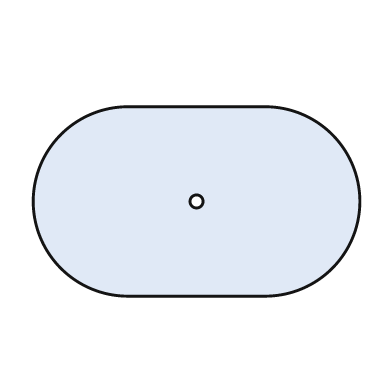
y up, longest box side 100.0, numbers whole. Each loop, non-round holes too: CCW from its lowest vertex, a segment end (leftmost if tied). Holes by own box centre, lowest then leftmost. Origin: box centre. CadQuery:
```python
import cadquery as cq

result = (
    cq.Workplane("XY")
    .moveTo(-21.0, -29.0)
    .lineTo(21.0, -29.0)
    .threePointArc((50.0, 0.0), (21.0, 29.0))
    .lineTo(-21.0, 29.0)
    .threePointArc((-50.0, 0.0), (-21.0, -29.0))
    .close()
    .moveTo(0.0, 0.0)
    .circle(2.0)
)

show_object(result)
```